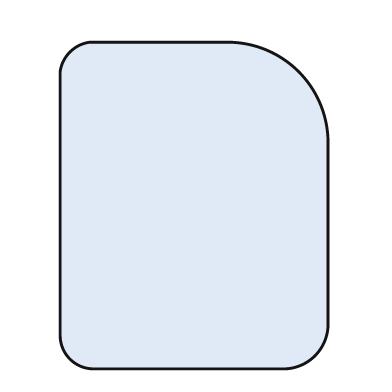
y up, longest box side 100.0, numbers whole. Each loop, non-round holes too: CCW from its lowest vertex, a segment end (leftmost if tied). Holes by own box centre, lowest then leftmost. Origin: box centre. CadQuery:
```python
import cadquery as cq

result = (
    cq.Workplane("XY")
    .moveTo(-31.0, -50.0)
    .lineTo(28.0, -50.0)
    .threePointArc((37.0, -46.0), (41.0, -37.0))
    .lineTo(41.0, 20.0)
    .threePointArc((32.0, 41.0), (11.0, 50.0))
    .lineTo(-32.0, 50.0)
    .threePointArc((-38.0, 47.0), (-41.0, 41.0))
    .lineTo(-41.0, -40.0)
    .threePointArc((-38.0, -47.0), (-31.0, -50.0))
    .close()
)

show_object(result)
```